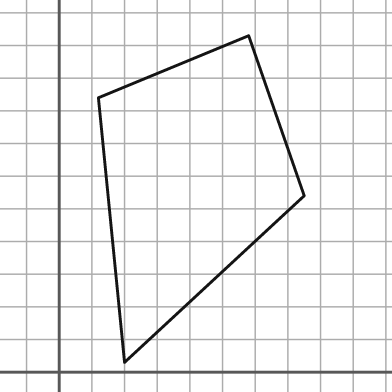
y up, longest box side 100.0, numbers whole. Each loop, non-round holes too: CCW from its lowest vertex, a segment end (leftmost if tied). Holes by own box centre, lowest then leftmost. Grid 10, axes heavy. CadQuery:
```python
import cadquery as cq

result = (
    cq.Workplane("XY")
    .moveTo(20.0, 3.0)
    .lineTo(75.0, 54.0)
    .lineTo(58.0, 103.0)
    .lineTo(12.0, 84.0)
    .close()
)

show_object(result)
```